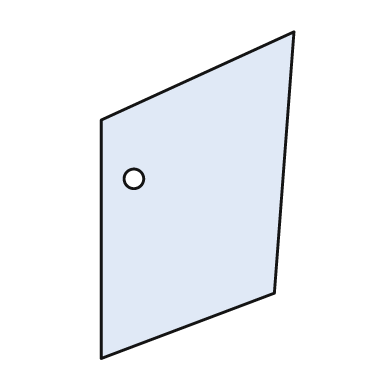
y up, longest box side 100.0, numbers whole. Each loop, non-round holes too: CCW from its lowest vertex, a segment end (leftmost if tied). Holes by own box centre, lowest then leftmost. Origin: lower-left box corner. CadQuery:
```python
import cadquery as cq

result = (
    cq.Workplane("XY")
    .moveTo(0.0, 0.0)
    .lineTo(53.0, 20.0)
    .lineTo(59.0, 100.0)
    .lineTo(0.0, 73.0)
    .close()
    .moveTo(10.0, 55.0)
    .circle(3.0)
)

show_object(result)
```